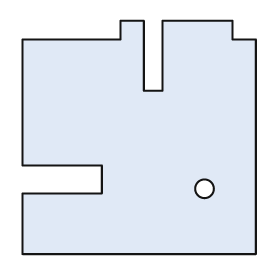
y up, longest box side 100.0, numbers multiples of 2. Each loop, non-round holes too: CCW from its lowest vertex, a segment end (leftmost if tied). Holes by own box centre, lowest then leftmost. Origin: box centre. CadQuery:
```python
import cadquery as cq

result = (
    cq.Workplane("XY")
    .moveTo(-50.0, -50.0)
    .lineTo(50.0, -50.0)
    .lineTo(50.0, 42.0)
    .lineTo(40.0, 42.0)
    .lineTo(40.0, 50.0)
    .lineTo(10.0, 50.0)
    .lineTo(10.0, 20.0)
    .lineTo(2.0, 20.0)
    .lineTo(2.0, 50.0)
    .lineTo(-8.0, 50.0)
    .lineTo(-8.0, 42.0)
    .lineTo(-50.0, 42.0)
    .lineTo(-50.0, -12.0)
    .lineTo(-16.0, -12.0)
    .lineTo(-16.0, -24.0)
    .lineTo(-50.0, -24.0)
    .close()
    .moveTo(28.0, -22.0)
    .circle(4.0)
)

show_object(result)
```